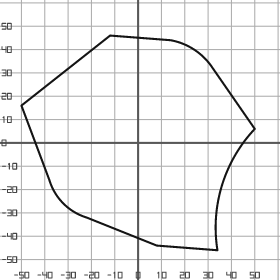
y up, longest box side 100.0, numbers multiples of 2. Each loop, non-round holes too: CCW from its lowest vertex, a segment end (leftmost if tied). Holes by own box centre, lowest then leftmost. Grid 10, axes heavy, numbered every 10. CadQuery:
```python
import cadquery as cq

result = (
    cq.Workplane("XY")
    .moveTo(34.0, -46.0)
    .threePointArc((36.0, -18.0), (50.0, 6.0))
    .lineTo(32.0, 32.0)
    .threePointArc((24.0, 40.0), (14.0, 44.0))
    .lineTo(-12.0, 46.0)
    .lineTo(-50.0, 16.0)
    .lineTo(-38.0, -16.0)
    .threePointArc((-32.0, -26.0), (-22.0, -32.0))
    .lineTo(8.0, -44.0)
    .close()
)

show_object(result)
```